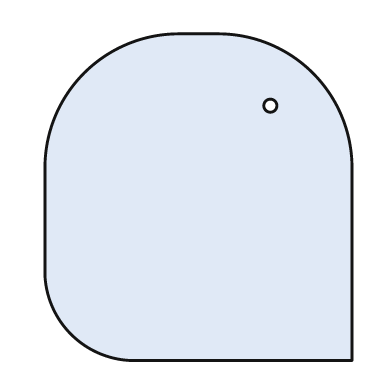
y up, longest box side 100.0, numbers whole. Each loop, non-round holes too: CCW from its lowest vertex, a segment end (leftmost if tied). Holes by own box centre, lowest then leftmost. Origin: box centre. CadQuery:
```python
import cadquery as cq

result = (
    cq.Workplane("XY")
    .moveTo(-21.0, -50.0)
    .lineTo(47.0, -50.0)
    .lineTo(47.0, 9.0)
    .threePointArc((35.0, 38.0), (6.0, 50.0))
    .lineTo(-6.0, 50.0)
    .threePointArc((-35.0, 38.0), (-47.0, 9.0))
    .lineTo(-47.0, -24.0)
    .threePointArc((-39.0, -42.0), (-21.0, -50.0))
    .close()
    .moveTo(22.0, 28.0)
    .circle(2.0)
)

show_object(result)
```